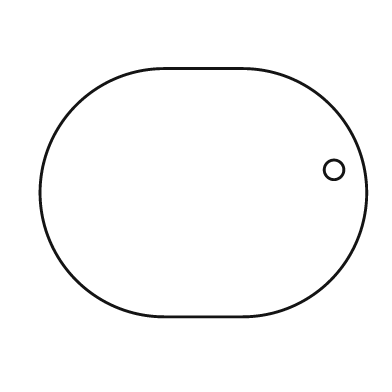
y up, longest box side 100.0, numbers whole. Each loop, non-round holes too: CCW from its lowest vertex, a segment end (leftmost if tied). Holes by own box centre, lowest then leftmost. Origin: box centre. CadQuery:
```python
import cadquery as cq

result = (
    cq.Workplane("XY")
    .moveTo(-12.0, -38.0)
    .lineTo(12.0, -38.0)
    .threePointArc((50.0, 0.0), (12.0, 38.0))
    .lineTo(-12.0, 38.0)
    .threePointArc((-50.0, 0.0), (-12.0, -38.0))
    .close()
    .moveTo(40.0, 7.0)
    .circle(3.0)
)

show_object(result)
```